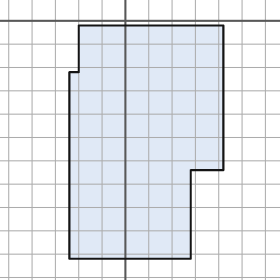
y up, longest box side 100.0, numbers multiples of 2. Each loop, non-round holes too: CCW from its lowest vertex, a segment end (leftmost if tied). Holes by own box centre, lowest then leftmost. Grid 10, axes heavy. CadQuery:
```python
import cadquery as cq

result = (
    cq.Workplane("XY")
    .moveTo(-24.0, -102.0)
    .lineTo(28.0, -102.0)
    .lineTo(28.0, -64.0)
    .lineTo(42.0, -64.0)
    .lineTo(42.0, -2.0)
    .lineTo(-20.0, -2.0)
    .lineTo(-20.0, -22.0)
    .lineTo(-24.0, -22.0)
    .close()
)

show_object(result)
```